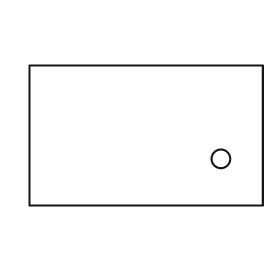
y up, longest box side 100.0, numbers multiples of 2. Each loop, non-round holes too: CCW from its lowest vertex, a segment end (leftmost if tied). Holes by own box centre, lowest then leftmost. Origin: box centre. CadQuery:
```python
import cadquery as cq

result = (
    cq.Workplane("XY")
    .moveTo(-50.0, -30.0)
    .lineTo(50.0, -30.0)
    .lineTo(50.0, 30.0)
    .lineTo(-50.0, 30.0)
    .close()
    .moveTo(32.0, -10.0)
    .circle(4.0)
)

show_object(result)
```